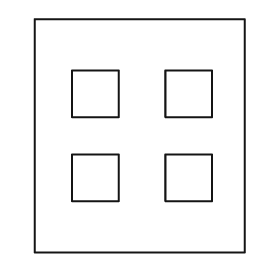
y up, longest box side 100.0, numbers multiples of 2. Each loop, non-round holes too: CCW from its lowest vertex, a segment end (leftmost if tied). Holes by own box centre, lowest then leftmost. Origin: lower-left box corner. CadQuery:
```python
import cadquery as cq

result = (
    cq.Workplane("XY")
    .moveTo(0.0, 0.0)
    .lineTo(90.0, 0.0)
    .lineTo(90.0, 100.0)
    .lineTo(0.0, 100.0)
    .close()
    .moveTo(16.0, 22.0)
    .lineTo(36.0, 22.0)
    .lineTo(36.0, 42.0)
    .lineTo(16.0, 42.0)
    .close()
    .moveTo(56.0, 22.0)
    .lineTo(76.0, 22.0)
    .lineTo(76.0, 42.0)
    .lineTo(56.0, 42.0)
    .close()
    .moveTo(16.0, 58.0)
    .lineTo(36.0, 58.0)
    .lineTo(36.0, 78.0)
    .lineTo(16.0, 78.0)
    .close()
    .moveTo(56.0, 58.0)
    .lineTo(76.0, 58.0)
    .lineTo(76.0, 78.0)
    .lineTo(56.0, 78.0)
    .close()
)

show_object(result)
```